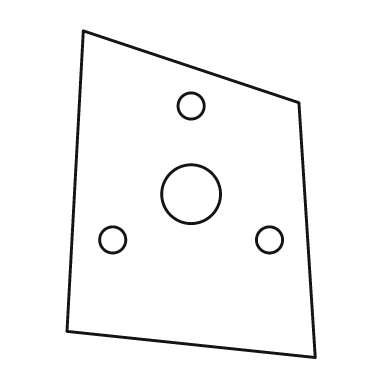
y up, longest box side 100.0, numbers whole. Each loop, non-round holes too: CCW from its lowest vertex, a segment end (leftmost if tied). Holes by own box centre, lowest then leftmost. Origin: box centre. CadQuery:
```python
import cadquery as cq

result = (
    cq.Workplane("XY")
    .moveTo(38.0, -50.0)
    .lineTo(33.0, 28.0)
    .lineTo(-33.0, 50.0)
    .lineTo(-38.0, -42.0)
    .close()
    .moveTo(-24.0, -14.0)
    .circle(4.0)
    .moveTo(24.0, -14.0)
    .circle(4.0)
    .moveTo(0.0, 0.0)
    .circle(9.0)
    .moveTo(0.0, 27.0)
    .circle(4.0)
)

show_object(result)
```